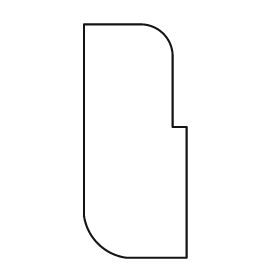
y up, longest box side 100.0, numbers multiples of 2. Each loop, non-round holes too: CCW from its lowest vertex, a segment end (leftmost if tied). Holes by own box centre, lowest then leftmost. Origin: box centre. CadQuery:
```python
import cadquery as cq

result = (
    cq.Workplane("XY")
    .moveTo(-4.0, -50.0)
    .lineTo(22.0, -50.0)
    .lineTo(22.0, 6.0)
    .lineTo(16.0, 6.0)
    .lineTo(16.0, 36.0)
    .threePointArc((12.0, 46.0), (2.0, 50.0))
    .lineTo(-22.0, 50.0)
    .lineTo(-22.0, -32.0)
    .threePointArc((-16.0, -44.0), (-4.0, -50.0))
    .close()
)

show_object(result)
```